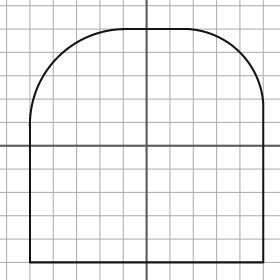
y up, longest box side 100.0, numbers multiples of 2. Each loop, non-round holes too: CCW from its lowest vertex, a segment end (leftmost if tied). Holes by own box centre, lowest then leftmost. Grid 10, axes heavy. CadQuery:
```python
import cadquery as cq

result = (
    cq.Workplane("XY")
    .moveTo(-50.0, -50.0)
    .lineTo(50.0, -50.0)
    .lineTo(50.0, 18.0)
    .threePointArc((40.0, 40.0), (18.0, 50.0))
    .lineTo(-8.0, 50.0)
    .threePointArc((-38.0, 38.0), (-50.0, 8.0))
    .close()
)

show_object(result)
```